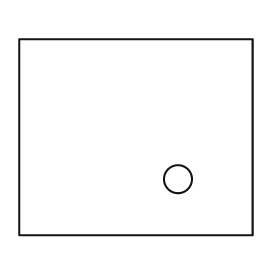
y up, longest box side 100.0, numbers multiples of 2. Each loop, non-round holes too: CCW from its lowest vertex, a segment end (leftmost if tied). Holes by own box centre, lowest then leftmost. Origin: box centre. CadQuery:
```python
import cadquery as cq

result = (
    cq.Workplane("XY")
    .moveTo(-50.0, -42.0)
    .lineTo(50.0, -42.0)
    .lineTo(50.0, 42.0)
    .lineTo(-50.0, 42.0)
    .close()
    .moveTo(18.0, -18.0)
    .circle(6.0)
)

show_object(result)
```